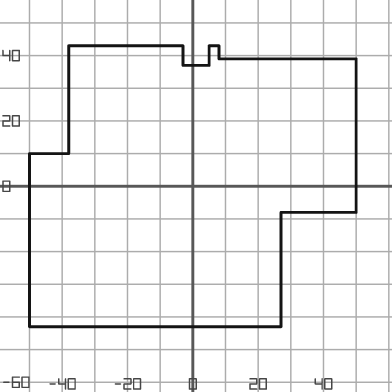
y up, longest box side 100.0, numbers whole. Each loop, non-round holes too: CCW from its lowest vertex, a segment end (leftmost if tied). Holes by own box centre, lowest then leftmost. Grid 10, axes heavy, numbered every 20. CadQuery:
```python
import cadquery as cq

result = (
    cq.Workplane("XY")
    .moveTo(-50.0, -43.0)
    .lineTo(27.0, -43.0)
    .lineTo(27.0, -8.0)
    .lineTo(50.0, -8.0)
    .lineTo(50.0, 39.0)
    .lineTo(8.0, 39.0)
    .lineTo(8.0, 43.0)
    .lineTo(5.0, 43.0)
    .lineTo(5.0, 37.0)
    .lineTo(-3.0, 37.0)
    .lineTo(-3.0, 43.0)
    .lineTo(-38.0, 43.0)
    .lineTo(-38.0, 10.0)
    .lineTo(-50.0, 10.0)
    .close()
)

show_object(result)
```